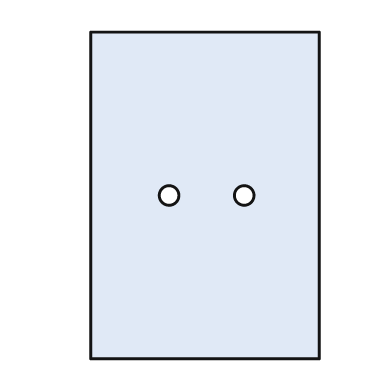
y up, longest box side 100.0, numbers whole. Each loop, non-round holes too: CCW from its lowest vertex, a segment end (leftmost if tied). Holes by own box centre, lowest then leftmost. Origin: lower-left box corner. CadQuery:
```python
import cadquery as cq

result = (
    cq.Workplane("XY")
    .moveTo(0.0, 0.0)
    .lineTo(70.0, 0.0)
    .lineTo(70.0, 100.0)
    .lineTo(0.0, 100.0)
    .close()
    .moveTo(24.0, 50.0)
    .circle(3.0)
    .moveTo(47.0, 50.0)
    .circle(3.0)
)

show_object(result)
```